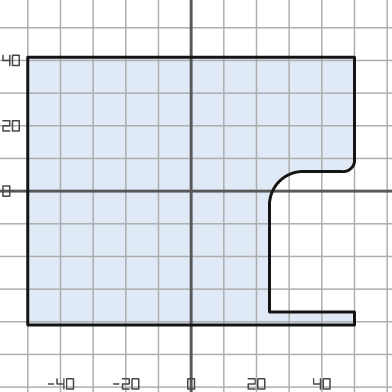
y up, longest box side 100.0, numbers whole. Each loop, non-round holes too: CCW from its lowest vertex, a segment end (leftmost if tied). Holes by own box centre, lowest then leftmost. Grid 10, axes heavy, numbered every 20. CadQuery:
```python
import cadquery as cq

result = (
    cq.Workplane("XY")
    .moveTo(-50.0, -41.0)
    .lineTo(50.0, -41.0)
    .lineTo(50.0, -37.0)
    .lineTo(24.0, -37.0)
    .lineTo(24.0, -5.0)
    .threePointArc((27.0, 3.0), (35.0, 6.0))
    .lineTo(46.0, 6.0)
    .threePointArc((49.0, 7.0), (50.0, 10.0))
    .lineTo(50.0, 41.0)
    .lineTo(-50.0, 41.0)
    .close()
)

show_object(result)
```